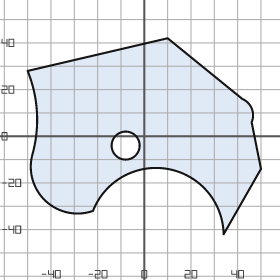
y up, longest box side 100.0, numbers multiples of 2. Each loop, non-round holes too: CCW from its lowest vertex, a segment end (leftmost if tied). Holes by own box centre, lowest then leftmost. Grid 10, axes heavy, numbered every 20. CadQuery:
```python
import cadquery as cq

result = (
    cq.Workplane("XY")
    .moveTo(34.0, -42.0)
    .lineTo(50.0, -14.0)
    .lineTo(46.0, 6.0)
    .threePointArc((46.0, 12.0), (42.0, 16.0))
    .lineTo(10.0, 42.0)
    .lineTo(-50.0, 28.0)
    .threePointArc((-46.0, 10.0), (-48.0, -8.0))
    .threePointArc((-42.0, -28.0), (-22.0, -32.0))
    .threePointArc((10.0, -14.0), (34.0, -42.0))
    .close()
    .moveTo(-8.0, -4.0)
    .circle(6.0)
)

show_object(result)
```